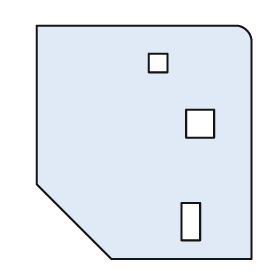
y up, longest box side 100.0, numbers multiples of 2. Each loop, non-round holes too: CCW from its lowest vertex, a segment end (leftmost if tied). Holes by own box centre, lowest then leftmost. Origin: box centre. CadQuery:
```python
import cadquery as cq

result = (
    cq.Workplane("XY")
    .moveTo(-14.0, -50.0)
    .lineTo(46.0, -50.0)
    .lineTo(46.0, 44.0)
    .threePointArc((44.0, 48.0), (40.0, 50.0))
    .lineTo(-46.0, 50.0)
    .lineTo(-46.0, -18.0)
    .close()
    .moveTo(16.0, -42.0)
    .lineTo(24.0, -42.0)
    .lineTo(24.0, -26.0)
    .lineTo(16.0, -26.0)
    .close()
    .moveTo(18.0, 2.0)
    .lineTo(30.0, 2.0)
    .lineTo(30.0, 14.0)
    .lineTo(18.0, 14.0)
    .close()
    .moveTo(2.0, 30.0)
    .lineTo(10.0, 30.0)
    .lineTo(10.0, 38.0)
    .lineTo(2.0, 38.0)
    .close()
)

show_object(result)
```